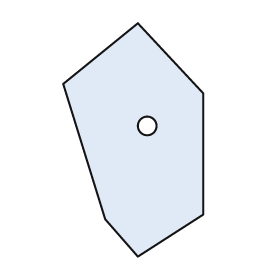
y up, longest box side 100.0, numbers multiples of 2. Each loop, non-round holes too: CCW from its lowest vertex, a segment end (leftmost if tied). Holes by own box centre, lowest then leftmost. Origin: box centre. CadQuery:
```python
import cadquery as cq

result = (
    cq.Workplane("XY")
    .moveTo(2.0, -50.0)
    .lineTo(30.0, -32.0)
    .lineTo(30.0, 20.0)
    .lineTo(2.0, 50.0)
    .lineTo(-30.0, 24.0)
    .lineTo(-12.0, -34.0)
    .close()
    .moveTo(6.0, 6.0)
    .circle(4.0)
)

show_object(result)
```